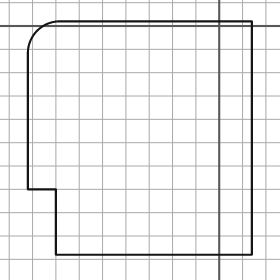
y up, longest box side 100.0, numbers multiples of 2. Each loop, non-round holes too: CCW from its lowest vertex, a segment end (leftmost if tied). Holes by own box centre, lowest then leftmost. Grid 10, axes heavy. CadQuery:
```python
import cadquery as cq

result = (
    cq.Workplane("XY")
    .moveTo(-70.0, -98.0)
    .lineTo(14.0, -98.0)
    .lineTo(14.0, 2.0)
    .lineTo(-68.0, 2.0)
    .threePointArc((-78.0, -2.0), (-82.0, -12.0))
    .lineTo(-82.0, -70.0)
    .lineTo(-70.0, -70.0)
    .close()
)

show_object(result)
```